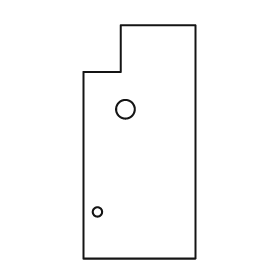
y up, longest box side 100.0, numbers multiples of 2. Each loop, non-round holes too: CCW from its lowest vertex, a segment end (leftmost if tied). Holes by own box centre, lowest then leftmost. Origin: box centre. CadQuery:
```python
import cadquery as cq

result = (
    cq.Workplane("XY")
    .moveTo(-24.0, -50.0)
    .lineTo(24.0, -50.0)
    .lineTo(24.0, 50.0)
    .lineTo(-8.0, 50.0)
    .lineTo(-8.0, 30.0)
    .lineTo(-24.0, 30.0)
    .close()
    .moveTo(-18.0, -30.0)
    .circle(2.0)
    .moveTo(-6.0, 14.0)
    .circle(4.0)
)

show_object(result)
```